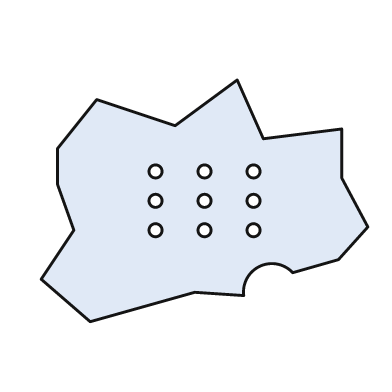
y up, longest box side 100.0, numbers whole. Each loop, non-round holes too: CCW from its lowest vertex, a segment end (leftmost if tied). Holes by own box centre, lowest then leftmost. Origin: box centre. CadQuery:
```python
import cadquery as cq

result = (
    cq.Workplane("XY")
    .moveTo(-35.0, -37.0)
    .lineTo(-3.0, -28.0)
    .lineTo(12.0, -29.0)
    .threePointArc((17.0, -20.0), (27.0, -22.0))
    .lineTo(41.0, -18.0)
    .lineTo(50.0, -8.0)
    .lineTo(42.0, 7.0)
    .lineTo(42.0, 22.0)
    .lineTo(18.0, 19.0)
    .lineTo(10.0, 37.0)
    .lineTo(-9.0, 23.0)
    .lineTo(-33.0, 31.0)
    .lineTo(-45.0, 16.0)
    .lineTo(-45.0, 5.0)
    .lineTo(-40.0, -9.0)
    .lineTo(-50.0, -24.0)
    .close()
    .moveTo(-15.0, -9.0)
    .circle(2.0)
    .moveTo(0.0, -9.0)
    .circle(2.0)
    .moveTo(15.0, -9.0)
    .circle(2.0)
    .moveTo(-15.0, 0.0)
    .circle(2.0)
    .moveTo(0.0, 0.0)
    .circle(2.0)
    .moveTo(15.0, 0.0)
    .circle(2.0)
    .moveTo(-15.0, 9.0)
    .circle(2.0)
    .moveTo(0.0, 9.0)
    .circle(2.0)
    .moveTo(15.0, 9.0)
    .circle(2.0)
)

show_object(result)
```